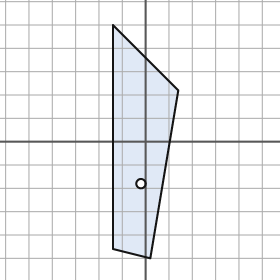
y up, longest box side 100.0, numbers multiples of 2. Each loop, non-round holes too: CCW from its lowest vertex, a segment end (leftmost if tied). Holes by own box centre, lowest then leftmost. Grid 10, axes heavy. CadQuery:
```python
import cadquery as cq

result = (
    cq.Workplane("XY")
    .moveTo(2.0, -50.0)
    .lineTo(14.0, 22.0)
    .lineTo(-14.0, 50.0)
    .lineTo(-14.0, -46.0)
    .close()
    .moveTo(-2.0, -18.0)
    .circle(2.0)
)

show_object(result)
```